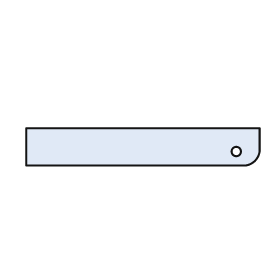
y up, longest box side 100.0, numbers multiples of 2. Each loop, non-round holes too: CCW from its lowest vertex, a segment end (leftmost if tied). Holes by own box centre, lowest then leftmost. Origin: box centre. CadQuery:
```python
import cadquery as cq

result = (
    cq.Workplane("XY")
    .moveTo(-50.0, -8.0)
    .lineTo(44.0, -8.0)
    .threePointArc((48.0, -6.0), (50.0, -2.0))
    .lineTo(50.0, 8.0)
    .lineTo(-50.0, 8.0)
    .close()
    .moveTo(40.0, -2.0)
    .circle(2.0)
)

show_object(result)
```